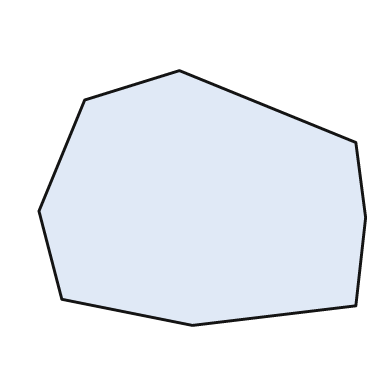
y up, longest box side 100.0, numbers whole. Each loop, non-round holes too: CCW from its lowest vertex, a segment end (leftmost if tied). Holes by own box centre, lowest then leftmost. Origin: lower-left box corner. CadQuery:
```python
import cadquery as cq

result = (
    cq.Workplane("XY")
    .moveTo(47.0, 0.0)
    .lineTo(97.0, 6.0)
    .lineTo(100.0, 33.0)
    .lineTo(97.0, 56.0)
    .lineTo(43.0, 78.0)
    .lineTo(14.0, 69.0)
    .lineTo(0.0, 35.0)
    .lineTo(7.0, 8.0)
    .close()
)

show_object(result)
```